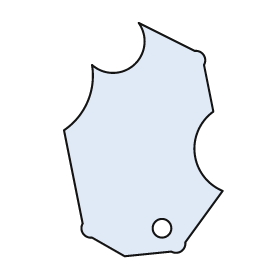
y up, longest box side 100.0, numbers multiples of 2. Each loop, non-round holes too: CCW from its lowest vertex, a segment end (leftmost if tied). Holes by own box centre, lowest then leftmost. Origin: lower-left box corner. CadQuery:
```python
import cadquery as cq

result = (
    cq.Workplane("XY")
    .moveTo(26.0, 0.0)
    .lineTo(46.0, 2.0)
    .threePointArc((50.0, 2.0), (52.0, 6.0))
    .lineTo(68.0, 28.0)
    .threePointArc((56.0, 44.0), (64.0, 62.0))
    .lineTo(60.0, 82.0)
    .threePointArc((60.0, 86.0), (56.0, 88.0))
    .lineTo(32.0, 100.0)
    .threePointArc((30.0, 82.0), (12.0, 82.0))
    .threePointArc((10.0, 66.0), (0.0, 54.0))
    .lineTo(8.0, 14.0)
    .threePointArc((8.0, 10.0), (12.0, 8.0))
    .close()
    .moveTo(42.0, 12.0)
    .circle(4.0)
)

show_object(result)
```